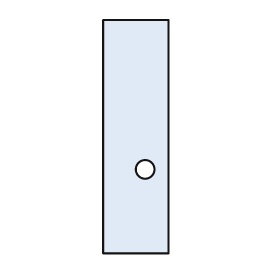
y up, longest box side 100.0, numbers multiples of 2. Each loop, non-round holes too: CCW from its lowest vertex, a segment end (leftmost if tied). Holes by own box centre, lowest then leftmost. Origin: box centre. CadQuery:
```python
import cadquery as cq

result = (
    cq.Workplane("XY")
    .moveTo(-14.0, -50.0)
    .lineTo(14.0, -50.0)
    .lineTo(14.0, 50.0)
    .lineTo(-14.0, 50.0)
    .close()
    .moveTo(4.0, -14.0)
    .circle(4.0)
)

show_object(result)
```